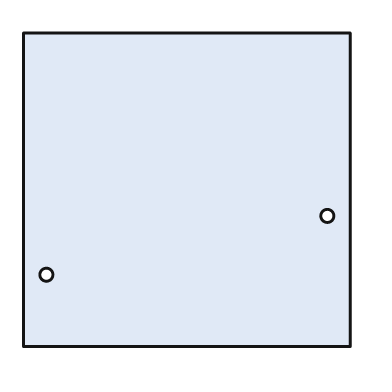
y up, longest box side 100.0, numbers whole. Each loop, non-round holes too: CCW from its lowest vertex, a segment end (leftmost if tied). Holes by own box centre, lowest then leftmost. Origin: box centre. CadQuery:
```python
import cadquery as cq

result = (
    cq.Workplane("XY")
    .moveTo(-50.0, -48.0)
    .lineTo(50.0, -48.0)
    .lineTo(50.0, 48.0)
    .lineTo(-50.0, 48.0)
    .close()
    .moveTo(-43.0, -26.0)
    .circle(2.0)
    .moveTo(43.0, -8.0)
    .circle(2.0)
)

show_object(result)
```